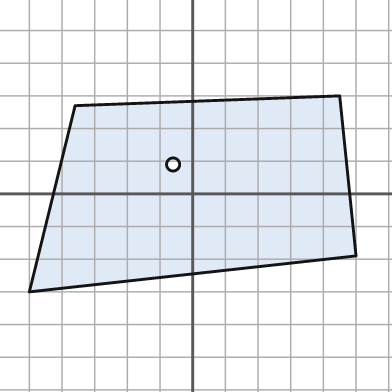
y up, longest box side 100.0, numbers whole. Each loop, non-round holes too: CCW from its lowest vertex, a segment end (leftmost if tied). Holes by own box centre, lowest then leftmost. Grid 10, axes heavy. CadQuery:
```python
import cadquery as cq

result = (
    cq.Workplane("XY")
    .moveTo(-50.0, -30.0)
    .lineTo(50.0, -19.0)
    .lineTo(45.0, 30.0)
    .lineTo(-36.0, 27.0)
    .close()
    .moveTo(-6.0, 9.0)
    .circle(2.0)
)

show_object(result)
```